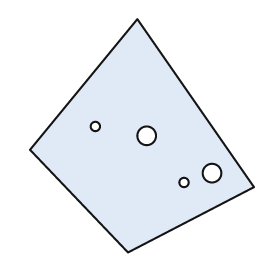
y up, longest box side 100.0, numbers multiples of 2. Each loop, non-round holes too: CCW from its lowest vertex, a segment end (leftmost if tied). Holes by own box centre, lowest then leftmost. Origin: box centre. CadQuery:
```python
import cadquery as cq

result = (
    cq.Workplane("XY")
    .moveTo(-6.0, -50.0)
    .lineTo(48.0, -22.0)
    .lineTo(-2.0, 50.0)
    .lineTo(-48.0, -6.0)
    .close()
    .moveTo(18.0, -20.0)
    .circle(2.0)
    .moveTo(30.0, -16.0)
    .circle(4.0)
    .moveTo(2.0, 0.0)
    .circle(4.0)
    .moveTo(-20.0, 4.0)
    .circle(2.0)
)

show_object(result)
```